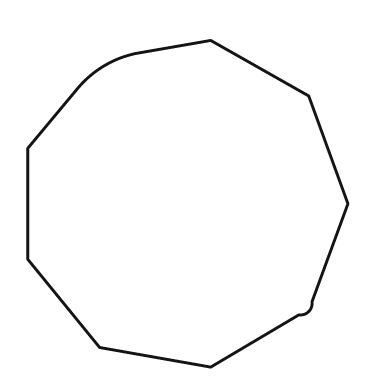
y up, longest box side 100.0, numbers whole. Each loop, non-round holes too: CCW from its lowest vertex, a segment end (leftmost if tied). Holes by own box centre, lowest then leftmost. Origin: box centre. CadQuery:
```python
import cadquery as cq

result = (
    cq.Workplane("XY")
    .moveTo(7.0, -50.0)
    .lineTo(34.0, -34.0)
    .threePointArc((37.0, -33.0), (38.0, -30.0))
    .lineTo(49.0, 0.0)
    .lineTo(37.0, 33.0)
    .lineTo(7.0, 50.0)
    .lineTo(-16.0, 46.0)
    .threePointArc((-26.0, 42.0), (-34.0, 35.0))
    .lineTo(-49.0, 17.0)
    .lineTo(-49.0, -17.0)
    .lineTo(-27.0, -44.0)
    .close()
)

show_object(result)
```